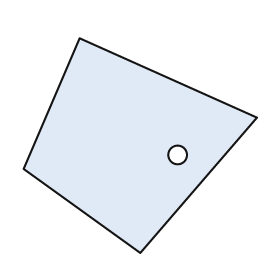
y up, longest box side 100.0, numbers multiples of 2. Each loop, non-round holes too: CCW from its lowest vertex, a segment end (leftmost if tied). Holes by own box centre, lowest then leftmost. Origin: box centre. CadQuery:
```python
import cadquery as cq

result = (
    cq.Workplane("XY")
    .moveTo(0.0, -46.0)
    .lineTo(50.0, 12.0)
    .lineTo(-26.0, 46.0)
    .lineTo(-50.0, -10.0)
    .close()
    .moveTo(16.0, -4.0)
    .circle(4.0)
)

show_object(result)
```